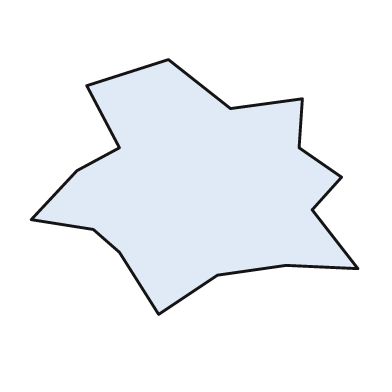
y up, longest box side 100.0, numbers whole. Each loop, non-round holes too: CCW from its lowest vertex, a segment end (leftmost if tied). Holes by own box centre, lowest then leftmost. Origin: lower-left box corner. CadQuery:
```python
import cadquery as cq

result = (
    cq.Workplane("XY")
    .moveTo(39.0, 0.0)
    .lineTo(57.0, 12.0)
    .lineTo(78.0, 15.0)
    .lineTo(100.0, 14.0)
    .lineTo(86.0, 32.0)
    .lineTo(95.0, 42.0)
    .lineTo(82.0, 51.0)
    .lineTo(83.0, 66.0)
    .lineTo(61.0, 63.0)
    .lineTo(42.0, 78.0)
    .lineTo(17.0, 70.0)
    .lineTo(27.0, 51.0)
    .lineTo(14.0, 44.0)
    .lineTo(0.0, 29.0)
    .lineTo(19.0, 26.0)
    .lineTo(27.0, 19.0)
    .close()
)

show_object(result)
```